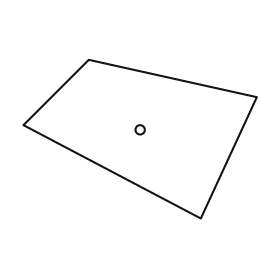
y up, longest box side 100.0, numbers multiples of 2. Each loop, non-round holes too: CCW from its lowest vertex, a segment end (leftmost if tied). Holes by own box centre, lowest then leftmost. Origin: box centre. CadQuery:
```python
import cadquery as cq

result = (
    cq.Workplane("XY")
    .moveTo(26.0, -34.0)
    .lineTo(50.0, 18.0)
    .lineTo(-22.0, 34.0)
    .lineTo(-50.0, 6.0)
    .close()
    .moveTo(0.0, 4.0)
    .circle(2.0)
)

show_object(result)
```